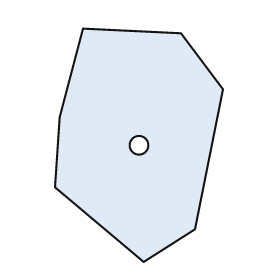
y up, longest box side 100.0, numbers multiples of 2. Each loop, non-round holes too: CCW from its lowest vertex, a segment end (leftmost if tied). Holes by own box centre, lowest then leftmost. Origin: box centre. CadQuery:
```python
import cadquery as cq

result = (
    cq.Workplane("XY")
    .moveTo(2.0, -50.0)
    .lineTo(24.0, -36.0)
    .lineTo(36.0, 24.0)
    .lineTo(18.0, 48.0)
    .lineTo(-24.0, 50.0)
    .lineTo(-34.0, 12.0)
    .lineTo(-36.0, -18.0)
    .close()
    .moveTo(0.0, 0.0)
    .circle(4.0)
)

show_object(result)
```